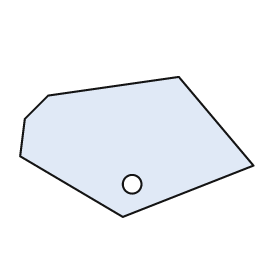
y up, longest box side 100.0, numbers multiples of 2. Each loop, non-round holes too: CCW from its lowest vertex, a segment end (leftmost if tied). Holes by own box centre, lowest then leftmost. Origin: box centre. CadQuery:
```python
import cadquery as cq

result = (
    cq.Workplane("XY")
    .moveTo(-6.0, -30.0)
    .lineTo(50.0, -8.0)
    .lineTo(18.0, 30.0)
    .lineTo(-38.0, 22.0)
    .lineTo(-48.0, 12.0)
    .lineTo(-50.0, -4.0)
    .close()
    .moveTo(-2.0, -16.0)
    .circle(4.0)
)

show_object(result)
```